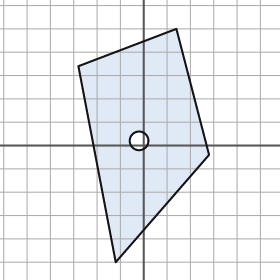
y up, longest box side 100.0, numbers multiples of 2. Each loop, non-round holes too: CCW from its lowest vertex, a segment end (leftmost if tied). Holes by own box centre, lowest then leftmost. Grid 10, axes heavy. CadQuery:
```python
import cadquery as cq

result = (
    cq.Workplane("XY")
    .moveTo(-12.0, -50.0)
    .lineTo(28.0, -4.0)
    .lineTo(14.0, 50.0)
    .lineTo(-28.0, 34.0)
    .close()
    .moveTo(-2.0, 2.0)
    .circle(4.0)
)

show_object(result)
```